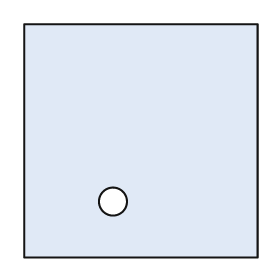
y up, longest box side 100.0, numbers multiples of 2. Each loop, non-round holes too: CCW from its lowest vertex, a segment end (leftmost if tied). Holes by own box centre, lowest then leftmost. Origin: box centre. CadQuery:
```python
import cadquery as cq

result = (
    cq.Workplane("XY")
    .moveTo(-50.0, -50.0)
    .lineTo(50.0, -50.0)
    .lineTo(50.0, 50.0)
    .lineTo(-50.0, 50.0)
    .close()
    .moveTo(-12.0, -26.0)
    .circle(6.0)
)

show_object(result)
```